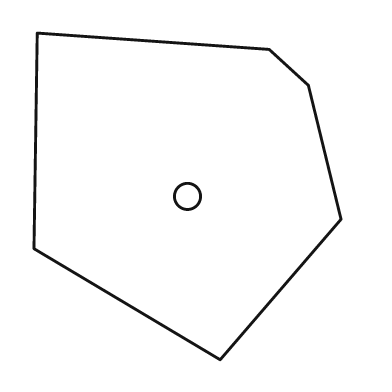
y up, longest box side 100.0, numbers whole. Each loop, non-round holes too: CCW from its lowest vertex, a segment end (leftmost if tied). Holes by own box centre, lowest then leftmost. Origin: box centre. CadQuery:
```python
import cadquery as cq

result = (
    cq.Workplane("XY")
    .moveTo(10.0, -50.0)
    .lineTo(47.0, -7.0)
    .lineTo(37.0, 34.0)
    .lineTo(25.0, 45.0)
    .lineTo(-46.0, 50.0)
    .lineTo(-47.0, -16.0)
    .close()
    .moveTo(0.0, 0.0)
    .circle(4.0)
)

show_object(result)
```